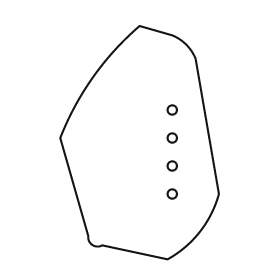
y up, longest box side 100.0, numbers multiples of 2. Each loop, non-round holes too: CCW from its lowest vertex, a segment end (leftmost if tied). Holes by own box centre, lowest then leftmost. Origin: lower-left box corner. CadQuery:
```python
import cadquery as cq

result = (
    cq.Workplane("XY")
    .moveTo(46.0, 0.0)
    .threePointArc((60.0, 12.0), (68.0, 28.0))
    .lineTo(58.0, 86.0)
    .threePointArc((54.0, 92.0), (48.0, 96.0))
    .lineTo(34.0, 100.0)
    .threePointArc((14.0, 78.0), (0.0, 52.0))
    .lineTo(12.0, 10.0)
    .threePointArc((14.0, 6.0), (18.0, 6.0))
    .close()
    .moveTo(48.0, 28.0)
    .circle(2.0)
    .moveTo(48.0, 40.0)
    .circle(2.0)
    .moveTo(48.0, 52.0)
    .circle(2.0)
    .moveTo(48.0, 64.0)
    .circle(2.0)
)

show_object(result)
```